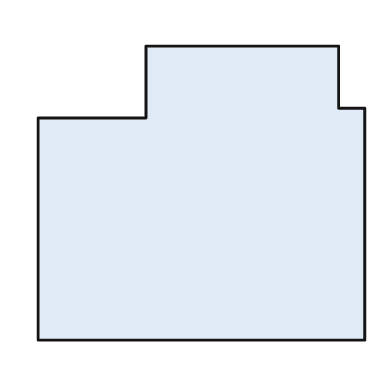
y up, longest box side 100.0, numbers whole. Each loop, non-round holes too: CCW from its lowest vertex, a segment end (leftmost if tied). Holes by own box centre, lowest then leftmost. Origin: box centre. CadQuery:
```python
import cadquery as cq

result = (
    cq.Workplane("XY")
    .moveTo(-50.0, -45.0)
    .lineTo(50.0, -45.0)
    .lineTo(50.0, 26.0)
    .lineTo(42.0, 26.0)
    .lineTo(42.0, 45.0)
    .lineTo(-17.0, 45.0)
    .lineTo(-17.0, 23.0)
    .lineTo(-50.0, 23.0)
    .close()
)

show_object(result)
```